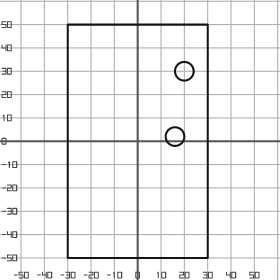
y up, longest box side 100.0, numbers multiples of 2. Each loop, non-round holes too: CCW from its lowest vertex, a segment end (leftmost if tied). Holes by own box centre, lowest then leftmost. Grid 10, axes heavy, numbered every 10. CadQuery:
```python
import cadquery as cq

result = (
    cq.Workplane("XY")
    .moveTo(-30.0, -50.0)
    .lineTo(30.0, -50.0)
    .lineTo(30.0, 50.0)
    .lineTo(-30.0, 50.0)
    .close()
    .moveTo(16.0, 2.0)
    .circle(4.0)
    .moveTo(20.0, 30.0)
    .circle(4.0)
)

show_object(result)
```